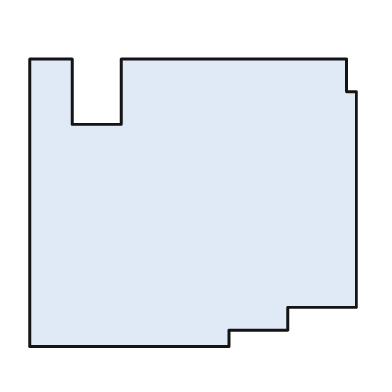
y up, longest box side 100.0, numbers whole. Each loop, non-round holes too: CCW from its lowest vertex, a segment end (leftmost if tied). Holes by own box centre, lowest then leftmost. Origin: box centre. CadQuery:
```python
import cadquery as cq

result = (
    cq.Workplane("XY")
    .moveTo(-50.0, -44.0)
    .lineTo(11.0, -44.0)
    .lineTo(11.0, -39.0)
    .lineTo(29.0, -39.0)
    .lineTo(29.0, -32.0)
    .lineTo(50.0, -32.0)
    .lineTo(50.0, 34.0)
    .lineTo(47.0, 34.0)
    .lineTo(47.0, 44.0)
    .lineTo(-22.0, 44.0)
    .lineTo(-22.0, 24.0)
    .lineTo(-37.0, 24.0)
    .lineTo(-37.0, 44.0)
    .lineTo(-50.0, 44.0)
    .close()
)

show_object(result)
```